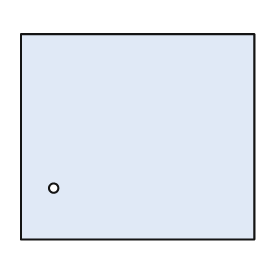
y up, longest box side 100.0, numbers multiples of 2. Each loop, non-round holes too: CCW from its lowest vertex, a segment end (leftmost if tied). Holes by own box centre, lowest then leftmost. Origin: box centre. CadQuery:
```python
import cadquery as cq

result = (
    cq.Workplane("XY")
    .moveTo(-50.0, -44.0)
    .lineTo(50.0, -44.0)
    .lineTo(50.0, 44.0)
    .lineTo(-50.0, 44.0)
    .close()
    .moveTo(-36.0, -22.0)
    .circle(2.0)
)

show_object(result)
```